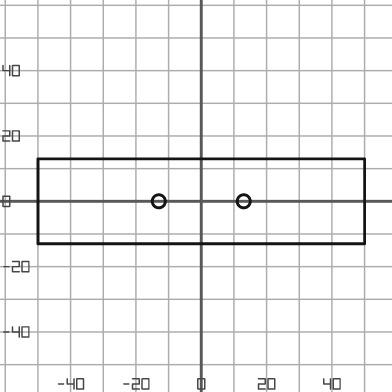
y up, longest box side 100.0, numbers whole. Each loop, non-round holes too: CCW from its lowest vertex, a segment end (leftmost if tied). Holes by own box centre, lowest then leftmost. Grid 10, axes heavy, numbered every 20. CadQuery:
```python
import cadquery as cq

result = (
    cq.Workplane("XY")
    .moveTo(-50.0, -13.0)
    .lineTo(50.0, -13.0)
    .lineTo(50.0, 13.0)
    .lineTo(-50.0, 13.0)
    .close()
    .moveTo(-13.0, 0.0)
    .circle(2.0)
    .moveTo(13.0, 0.0)
    .circle(2.0)
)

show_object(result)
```